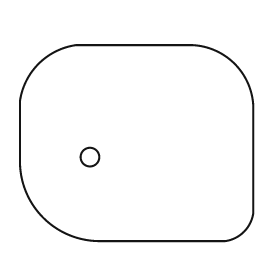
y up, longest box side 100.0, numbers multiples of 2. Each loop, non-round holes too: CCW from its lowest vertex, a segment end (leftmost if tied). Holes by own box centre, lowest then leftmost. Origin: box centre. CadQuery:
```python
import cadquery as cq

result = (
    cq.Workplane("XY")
    .moveTo(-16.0, -42.0)
    .lineTo(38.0, -42.0)
    .threePointArc((46.0, -38.0), (50.0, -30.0))
    .lineTo(50.0, 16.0)
    .threePointArc((42.0, 34.0), (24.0, 42.0))
    .lineTo(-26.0, 42.0)
    .threePointArc((-42.0, 34.0), (-50.0, 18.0))
    .lineTo(-50.0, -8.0)
    .threePointArc((-40.0, -32.0), (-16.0, -42.0))
    .close()
    .moveTo(-20.0, -6.0)
    .circle(4.0)
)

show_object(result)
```